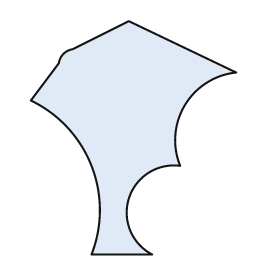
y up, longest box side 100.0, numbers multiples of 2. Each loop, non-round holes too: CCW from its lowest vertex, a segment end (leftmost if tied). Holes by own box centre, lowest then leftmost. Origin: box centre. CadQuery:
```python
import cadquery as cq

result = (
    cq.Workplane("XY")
    .moveTo(-18.0, -50.0)
    .lineTo(8.0, -50.0)
    .threePointArc((-2.0, -26.0), (20.0, -12.0))
    .threePointArc((22.0, 14.0), (44.0, 28.0))
    .lineTo(-2.0, 50.0)
    .lineTo(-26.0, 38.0)
    .threePointArc((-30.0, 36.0), (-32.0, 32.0))
    .lineTo(-44.0, 16.0)
    .threePointArc((-18.0, -12.0), (-18.0, -50.0))
    .close()
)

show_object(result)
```